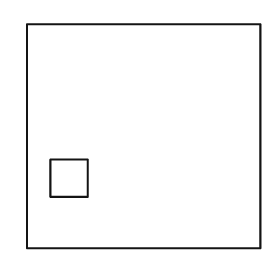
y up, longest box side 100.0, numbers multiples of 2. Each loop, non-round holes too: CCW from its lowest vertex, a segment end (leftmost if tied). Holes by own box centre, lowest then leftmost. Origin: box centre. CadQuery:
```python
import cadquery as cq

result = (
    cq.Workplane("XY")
    .moveTo(-50.0, -48.0)
    .lineTo(50.0, -48.0)
    .lineTo(50.0, 48.0)
    .lineTo(-50.0, 48.0)
    .close()
    .moveTo(-40.0, -26.0)
    .lineTo(-24.0, -26.0)
    .lineTo(-24.0, -10.0)
    .lineTo(-40.0, -10.0)
    .close()
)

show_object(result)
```